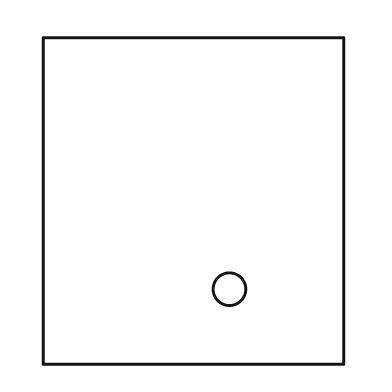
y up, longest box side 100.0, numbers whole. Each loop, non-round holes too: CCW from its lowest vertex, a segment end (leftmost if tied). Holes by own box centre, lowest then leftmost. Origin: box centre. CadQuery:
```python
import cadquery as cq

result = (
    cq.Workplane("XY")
    .moveTo(-46.0, -50.0)
    .lineTo(46.0, -50.0)
    .lineTo(46.0, 50.0)
    .lineTo(-46.0, 50.0)
    .close()
    .moveTo(11.0, -27.0)
    .circle(5.0)
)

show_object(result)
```